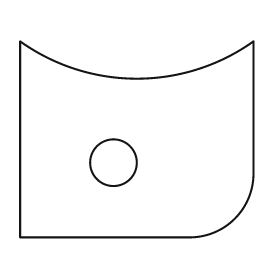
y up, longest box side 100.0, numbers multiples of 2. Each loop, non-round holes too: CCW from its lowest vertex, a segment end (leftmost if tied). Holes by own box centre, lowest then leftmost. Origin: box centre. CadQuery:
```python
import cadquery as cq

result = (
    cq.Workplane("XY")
    .moveTo(-50.0, -42.0)
    .lineTo(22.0, -42.0)
    .threePointArc((42.0, -34.0), (50.0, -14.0))
    .lineTo(50.0, 42.0)
    .threePointArc((0.0, 26.0), (-50.0, 42.0))
    .close()
    .moveTo(-10.0, -10.0)
    .circle(10.0)
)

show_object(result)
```